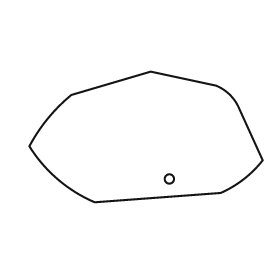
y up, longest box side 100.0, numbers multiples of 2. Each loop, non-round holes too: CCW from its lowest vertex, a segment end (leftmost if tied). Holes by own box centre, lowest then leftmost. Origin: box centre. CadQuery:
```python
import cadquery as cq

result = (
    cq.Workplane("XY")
    .moveTo(-22.0, -28.0)
    .lineTo(32.0, -24.0)
    .threePointArc((42.0, -18.0), (50.0, -10.0))
    .lineTo(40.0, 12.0)
    .threePointArc((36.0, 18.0), (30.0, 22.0))
    .lineTo(2.0, 28.0)
    .lineTo(-32.0, 18.0)
    .threePointArc((-42.0, 8.0), (-50.0, -4.0))
    .threePointArc((-38.0, -18.0), (-22.0, -28.0))
    .close()
    .moveTo(10.0, -18.0)
    .circle(2.0)
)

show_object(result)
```